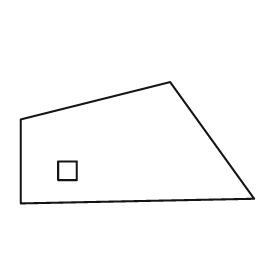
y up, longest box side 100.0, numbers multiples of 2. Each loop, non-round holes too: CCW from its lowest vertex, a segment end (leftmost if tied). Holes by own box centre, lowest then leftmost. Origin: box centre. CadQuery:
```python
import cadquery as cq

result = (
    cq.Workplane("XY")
    .moveTo(-50.0, -26.0)
    .lineTo(50.0, -24.0)
    .lineTo(14.0, 26.0)
    .lineTo(-50.0, 10.0)
    .close()
    .moveTo(-34.0, -16.0)
    .lineTo(-26.0, -16.0)
    .lineTo(-26.0, -8.0)
    .lineTo(-34.0, -8.0)
    .close()
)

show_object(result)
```